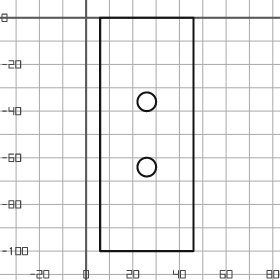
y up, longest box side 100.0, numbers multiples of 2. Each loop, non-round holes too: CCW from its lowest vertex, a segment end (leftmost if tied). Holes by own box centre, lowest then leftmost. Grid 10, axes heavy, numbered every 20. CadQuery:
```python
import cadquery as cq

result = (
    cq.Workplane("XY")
    .moveTo(6.0, -100.0)
    .lineTo(46.0, -100.0)
    .lineTo(46.0, 0.0)
    .lineTo(6.0, 0.0)
    .close()
    .moveTo(26.0, -64.0)
    .circle(4.0)
    .moveTo(26.0, -36.0)
    .circle(4.0)
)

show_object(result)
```